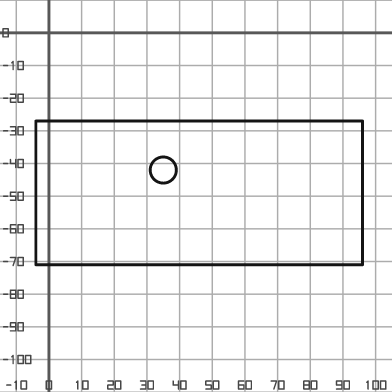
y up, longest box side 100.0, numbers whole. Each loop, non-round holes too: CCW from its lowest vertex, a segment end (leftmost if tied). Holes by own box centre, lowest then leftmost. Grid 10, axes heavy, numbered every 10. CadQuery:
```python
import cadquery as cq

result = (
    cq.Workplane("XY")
    .moveTo(-4.0, -71.0)
    .lineTo(96.0, -71.0)
    .lineTo(96.0, -27.0)
    .lineTo(-4.0, -27.0)
    .close()
    .moveTo(35.0, -42.0)
    .circle(4.0)
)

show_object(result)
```